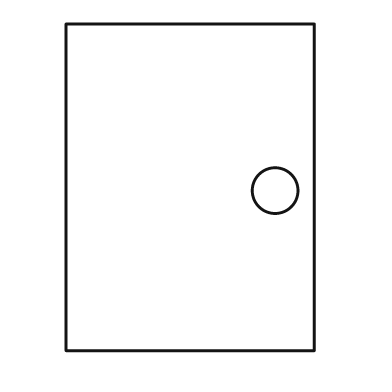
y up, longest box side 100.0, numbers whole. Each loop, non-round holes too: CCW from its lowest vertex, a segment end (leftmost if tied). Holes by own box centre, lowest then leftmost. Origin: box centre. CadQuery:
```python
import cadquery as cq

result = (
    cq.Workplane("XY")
    .moveTo(-38.0, -50.0)
    .lineTo(38.0, -50.0)
    .lineTo(38.0, 50.0)
    .lineTo(-38.0, 50.0)
    .close()
    .moveTo(26.0, -1.0)
    .circle(7.0)
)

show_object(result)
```